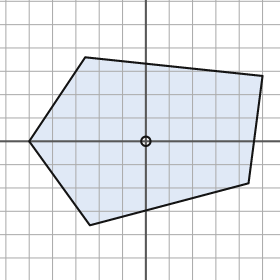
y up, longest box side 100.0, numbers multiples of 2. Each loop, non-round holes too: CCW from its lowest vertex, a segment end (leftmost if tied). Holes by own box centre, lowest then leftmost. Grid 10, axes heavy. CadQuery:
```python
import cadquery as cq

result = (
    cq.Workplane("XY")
    .moveTo(-24.0, -36.0)
    .lineTo(44.0, -18.0)
    .lineTo(50.0, 28.0)
    .lineTo(-26.0, 36.0)
    .lineTo(-50.0, 0.0)
    .close()
    .moveTo(0.0, 0.0)
    .circle(2.0)
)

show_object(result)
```